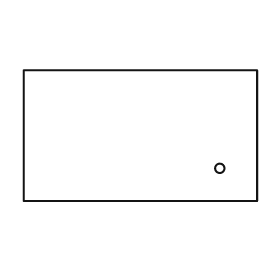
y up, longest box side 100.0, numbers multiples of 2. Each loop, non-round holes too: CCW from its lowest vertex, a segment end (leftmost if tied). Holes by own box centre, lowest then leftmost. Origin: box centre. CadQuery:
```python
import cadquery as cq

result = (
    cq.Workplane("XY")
    .moveTo(-50.0, -28.0)
    .lineTo(50.0, -28.0)
    .lineTo(50.0, 28.0)
    .lineTo(-50.0, 28.0)
    .close()
    .moveTo(34.0, -14.0)
    .circle(2.0)
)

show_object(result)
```